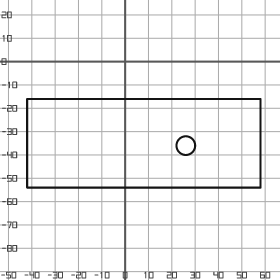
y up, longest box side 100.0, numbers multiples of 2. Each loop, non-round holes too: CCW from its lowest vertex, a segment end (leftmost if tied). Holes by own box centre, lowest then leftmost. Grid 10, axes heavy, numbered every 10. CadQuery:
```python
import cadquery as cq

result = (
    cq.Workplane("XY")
    .moveTo(-42.0, -54.0)
    .lineTo(58.0, -54.0)
    .lineTo(58.0, -16.0)
    .lineTo(-42.0, -16.0)
    .close()
    .moveTo(26.0, -36.0)
    .circle(4.0)
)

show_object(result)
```